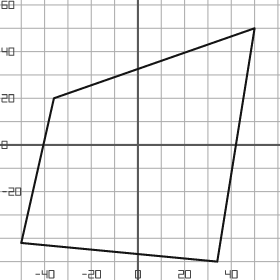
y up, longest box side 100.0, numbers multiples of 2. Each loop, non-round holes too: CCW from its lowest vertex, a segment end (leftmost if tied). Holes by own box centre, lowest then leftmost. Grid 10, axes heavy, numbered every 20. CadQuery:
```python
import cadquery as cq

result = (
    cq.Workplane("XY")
    .moveTo(34.0, -50.0)
    .lineTo(50.0, 50.0)
    .lineTo(-36.0, 20.0)
    .lineTo(-50.0, -42.0)
    .close()
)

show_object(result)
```